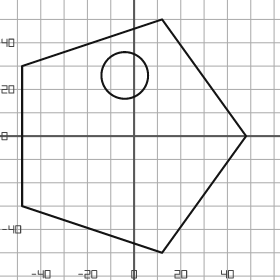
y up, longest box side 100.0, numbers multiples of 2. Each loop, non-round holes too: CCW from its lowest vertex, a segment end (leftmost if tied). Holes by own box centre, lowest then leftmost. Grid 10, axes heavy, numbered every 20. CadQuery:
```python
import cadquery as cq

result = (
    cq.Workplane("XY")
    .moveTo(12.0, -50.0)
    .lineTo(48.0, 0.0)
    .lineTo(12.0, 50.0)
    .lineTo(-48.0, 30.0)
    .lineTo(-48.0, -30.0)
    .close()
    .moveTo(-4.0, 26.0)
    .circle(10.0)
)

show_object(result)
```